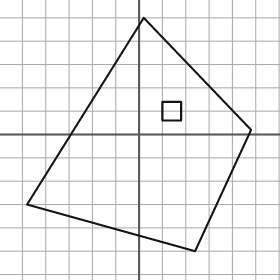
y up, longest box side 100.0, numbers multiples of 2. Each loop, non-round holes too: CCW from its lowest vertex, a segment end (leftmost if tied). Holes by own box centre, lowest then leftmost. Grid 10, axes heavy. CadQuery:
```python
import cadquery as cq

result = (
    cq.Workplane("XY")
    .moveTo(24.0, -50.0)
    .lineTo(48.0, 2.0)
    .lineTo(2.0, 50.0)
    .lineTo(-48.0, -30.0)
    .close()
    .moveTo(10.0, 6.0)
    .lineTo(18.0, 6.0)
    .lineTo(18.0, 14.0)
    .lineTo(10.0, 14.0)
    .close()
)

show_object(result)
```